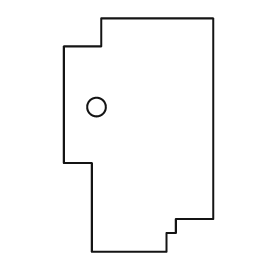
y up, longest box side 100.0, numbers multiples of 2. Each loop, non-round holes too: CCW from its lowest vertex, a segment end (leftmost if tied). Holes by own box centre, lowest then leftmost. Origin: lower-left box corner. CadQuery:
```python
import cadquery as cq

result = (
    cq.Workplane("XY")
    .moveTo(12.0, 0.0)
    .lineTo(44.0, 0.0)
    .lineTo(44.0, 8.0)
    .lineTo(48.0, 8.0)
    .lineTo(48.0, 14.0)
    .lineTo(64.0, 14.0)
    .lineTo(64.0, 100.0)
    .lineTo(16.0, 100.0)
    .lineTo(16.0, 88.0)
    .lineTo(0.0, 88.0)
    .lineTo(0.0, 38.0)
    .lineTo(12.0, 38.0)
    .close()
    .moveTo(14.0, 62.0)
    .circle(4.0)
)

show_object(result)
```